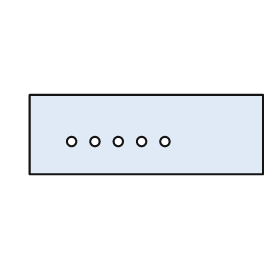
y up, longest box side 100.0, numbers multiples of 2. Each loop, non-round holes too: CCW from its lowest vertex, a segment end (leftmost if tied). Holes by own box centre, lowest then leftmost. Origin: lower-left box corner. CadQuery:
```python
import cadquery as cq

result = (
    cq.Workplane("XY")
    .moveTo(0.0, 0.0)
    .lineTo(100.0, 0.0)
    .lineTo(100.0, 34.0)
    .lineTo(0.0, 34.0)
    .close()
    .moveTo(18.0, 14.0)
    .circle(2.0)
    .moveTo(28.0, 14.0)
    .circle(2.0)
    .moveTo(38.0, 14.0)
    .circle(2.0)
    .moveTo(48.0, 14.0)
    .circle(2.0)
    .moveTo(58.0, 14.0)
    .circle(2.0)
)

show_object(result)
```